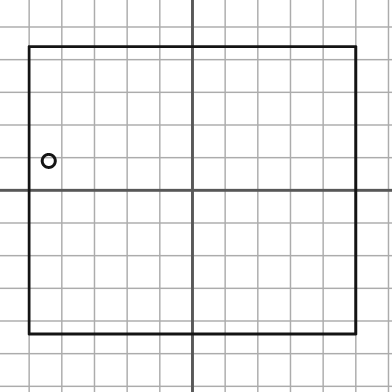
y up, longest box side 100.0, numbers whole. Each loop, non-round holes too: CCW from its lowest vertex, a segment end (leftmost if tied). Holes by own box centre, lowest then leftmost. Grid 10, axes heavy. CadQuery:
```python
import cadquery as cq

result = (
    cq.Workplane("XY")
    .moveTo(-50.0, -44.0)
    .lineTo(50.0, -44.0)
    .lineTo(50.0, 44.0)
    .lineTo(-50.0, 44.0)
    .close()
    .moveTo(-44.0, 9.0)
    .circle(2.0)
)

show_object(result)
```